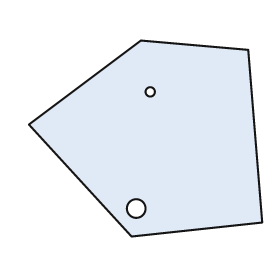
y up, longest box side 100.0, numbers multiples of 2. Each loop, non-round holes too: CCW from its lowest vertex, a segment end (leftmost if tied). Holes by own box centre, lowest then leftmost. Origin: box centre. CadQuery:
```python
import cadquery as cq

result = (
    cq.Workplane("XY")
    .moveTo(-6.0, -42.0)
    .lineTo(50.0, -36.0)
    .lineTo(44.0, 38.0)
    .lineTo(-2.0, 42.0)
    .lineTo(-50.0, 6.0)
    .close()
    .moveTo(-4.0, -30.0)
    .circle(4.0)
    .moveTo(2.0, 20.0)
    .circle(2.0)
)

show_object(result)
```